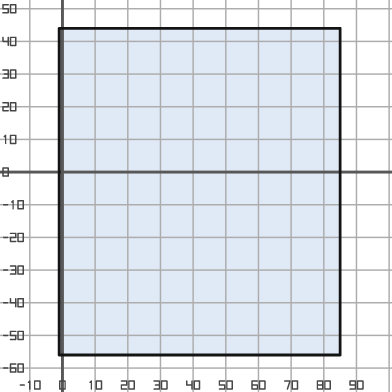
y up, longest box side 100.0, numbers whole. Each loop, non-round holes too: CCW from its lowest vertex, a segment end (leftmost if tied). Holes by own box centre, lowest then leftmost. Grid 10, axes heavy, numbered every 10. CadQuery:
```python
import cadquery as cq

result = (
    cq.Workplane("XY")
    .moveTo(-1.0, -56.0)
    .lineTo(85.0, -56.0)
    .lineTo(85.0, 44.0)
    .lineTo(-1.0, 44.0)
    .close()
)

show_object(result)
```